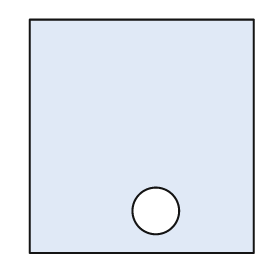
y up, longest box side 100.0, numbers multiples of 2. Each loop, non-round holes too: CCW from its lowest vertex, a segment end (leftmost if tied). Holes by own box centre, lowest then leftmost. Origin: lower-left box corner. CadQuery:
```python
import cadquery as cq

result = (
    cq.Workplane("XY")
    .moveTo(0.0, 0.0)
    .lineTo(96.0, 0.0)
    .lineTo(96.0, 100.0)
    .lineTo(0.0, 100.0)
    .close()
    .moveTo(54.0, 18.0)
    .circle(10.0)
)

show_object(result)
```